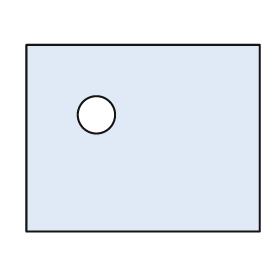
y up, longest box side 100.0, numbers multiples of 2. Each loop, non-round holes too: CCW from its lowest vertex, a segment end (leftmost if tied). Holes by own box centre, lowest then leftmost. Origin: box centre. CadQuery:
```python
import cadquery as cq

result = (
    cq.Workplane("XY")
    .moveTo(-50.0, -40.0)
    .lineTo(50.0, -40.0)
    .lineTo(50.0, 40.0)
    .lineTo(-50.0, 40.0)
    .close()
    .moveTo(-20.0, 10.0)
    .circle(8.0)
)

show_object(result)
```